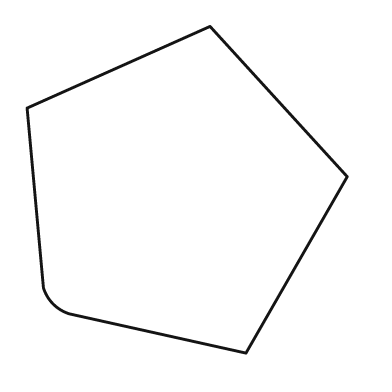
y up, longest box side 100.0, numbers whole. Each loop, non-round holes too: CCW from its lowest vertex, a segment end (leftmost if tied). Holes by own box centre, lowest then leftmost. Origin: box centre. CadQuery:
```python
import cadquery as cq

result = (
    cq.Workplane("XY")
    .moveTo(18.0, -50.0)
    .lineTo(49.0, 4.0)
    .lineTo(7.0, 50.0)
    .lineTo(-49.0, 25.0)
    .lineTo(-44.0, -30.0)
    .threePointArc((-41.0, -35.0), (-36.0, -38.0))
    .close()
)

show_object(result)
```